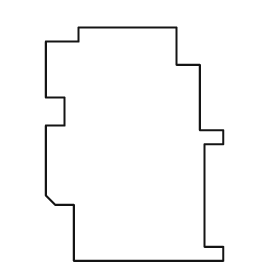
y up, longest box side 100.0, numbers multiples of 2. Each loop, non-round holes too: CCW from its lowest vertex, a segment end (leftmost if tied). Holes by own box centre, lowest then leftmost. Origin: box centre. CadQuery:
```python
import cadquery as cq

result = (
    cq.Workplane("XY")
    .moveTo(-26.0, -50.0)
    .lineTo(38.0, -50.0)
    .lineTo(38.0, -44.0)
    .lineTo(30.0, -44.0)
    .lineTo(30.0, 0.0)
    .lineTo(38.0, 0.0)
    .lineTo(38.0, 6.0)
    .lineTo(28.0, 6.0)
    .lineTo(28.0, 34.0)
    .lineTo(18.0, 34.0)
    .lineTo(18.0, 50.0)
    .lineTo(-24.0, 50.0)
    .lineTo(-24.0, 44.0)
    .lineTo(-38.0, 44.0)
    .lineTo(-38.0, 20.0)
    .lineTo(-30.0, 20.0)
    .lineTo(-30.0, 8.0)
    .lineTo(-38.0, 8.0)
    .lineTo(-38.0, -22.0)
    .lineTo(-34.0, -26.0)
    .lineTo(-26.0, -26.0)
    .close()
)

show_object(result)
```